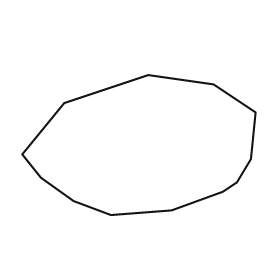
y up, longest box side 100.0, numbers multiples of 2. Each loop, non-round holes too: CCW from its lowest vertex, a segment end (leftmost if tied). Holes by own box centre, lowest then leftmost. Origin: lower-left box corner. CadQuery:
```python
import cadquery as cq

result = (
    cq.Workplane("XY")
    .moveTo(38.0, 0.0)
    .lineTo(64.0, 2.0)
    .lineTo(86.0, 10.0)
    .lineTo(92.0, 14.0)
    .lineTo(98.0, 24.0)
    .lineTo(100.0, 44.0)
    .lineTo(82.0, 56.0)
    .lineTo(54.0, 60.0)
    .lineTo(18.0, 48.0)
    .lineTo(0.0, 26.0)
    .lineTo(8.0, 16.0)
    .lineTo(22.0, 6.0)
    .close()
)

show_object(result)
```